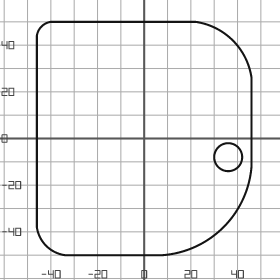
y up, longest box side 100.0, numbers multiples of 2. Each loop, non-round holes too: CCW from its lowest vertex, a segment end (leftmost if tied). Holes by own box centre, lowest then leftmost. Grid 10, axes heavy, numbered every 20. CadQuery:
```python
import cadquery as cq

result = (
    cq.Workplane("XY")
    .moveTo(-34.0, -50.0)
    .lineTo(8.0, -50.0)
    .threePointArc((34.0, -38.0), (46.0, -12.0))
    .lineTo(46.0, 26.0)
    .threePointArc((38.0, 42.0), (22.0, 50.0))
    .lineTo(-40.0, 50.0)
    .threePointArc((-44.0, 48.0), (-46.0, 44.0))
    .lineTo(-46.0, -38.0)
    .threePointArc((-42.0, -46.0), (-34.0, -50.0))
    .close()
    .moveTo(36.0, -8.0)
    .circle(6.0)
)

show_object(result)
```